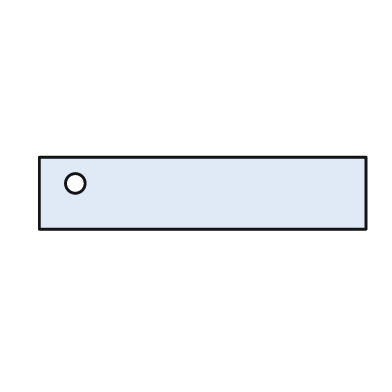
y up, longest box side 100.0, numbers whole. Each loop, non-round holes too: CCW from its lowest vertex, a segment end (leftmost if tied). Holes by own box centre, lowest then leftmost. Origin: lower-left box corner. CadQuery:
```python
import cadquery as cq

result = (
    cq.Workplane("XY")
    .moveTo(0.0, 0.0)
    .lineTo(100.0, 0.0)
    .lineTo(100.0, 22.0)
    .lineTo(0.0, 22.0)
    .close()
    .moveTo(11.0, 14.0)
    .circle(3.0)
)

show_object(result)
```